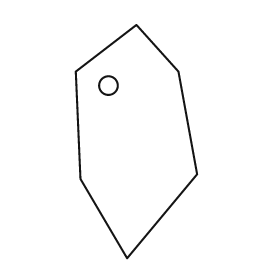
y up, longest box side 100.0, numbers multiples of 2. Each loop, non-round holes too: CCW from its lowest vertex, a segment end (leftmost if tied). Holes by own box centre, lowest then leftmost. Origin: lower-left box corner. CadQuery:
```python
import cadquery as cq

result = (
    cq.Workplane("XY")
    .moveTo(22.0, 0.0)
    .lineTo(52.0, 36.0)
    .lineTo(44.0, 80.0)
    .lineTo(26.0, 100.0)
    .lineTo(0.0, 80.0)
    .lineTo(2.0, 34.0)
    .close()
    .moveTo(14.0, 74.0)
    .circle(4.0)
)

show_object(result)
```